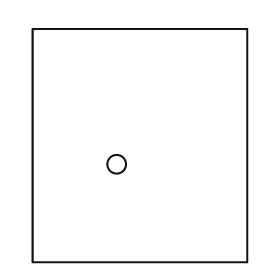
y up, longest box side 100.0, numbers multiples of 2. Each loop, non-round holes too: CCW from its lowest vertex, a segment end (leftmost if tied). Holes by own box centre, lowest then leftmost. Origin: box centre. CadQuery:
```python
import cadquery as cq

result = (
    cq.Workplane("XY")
    .moveTo(-46.0, -50.0)
    .lineTo(46.0, -50.0)
    .lineTo(46.0, 50.0)
    .lineTo(-46.0, 50.0)
    .close()
    .moveTo(-10.0, -8.0)
    .circle(4.0)
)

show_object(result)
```